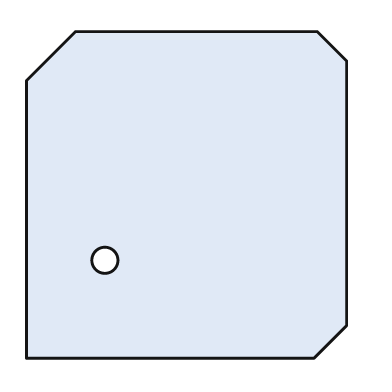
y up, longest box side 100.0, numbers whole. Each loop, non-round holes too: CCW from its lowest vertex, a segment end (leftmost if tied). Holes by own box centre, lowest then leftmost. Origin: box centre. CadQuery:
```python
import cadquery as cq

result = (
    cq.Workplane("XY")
    .moveTo(-49.0, -50.0)
    .lineTo(39.0, -50.0)
    .lineTo(49.0, -40.0)
    .lineTo(49.0, 41.0)
    .lineTo(40.0, 50.0)
    .lineTo(-34.0, 50.0)
    .lineTo(-49.0, 35.0)
    .close()
    .moveTo(-25.0, -20.0)
    .circle(4.0)
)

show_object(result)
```